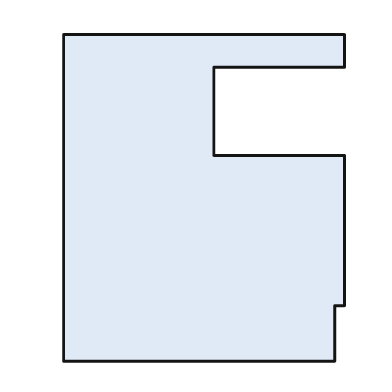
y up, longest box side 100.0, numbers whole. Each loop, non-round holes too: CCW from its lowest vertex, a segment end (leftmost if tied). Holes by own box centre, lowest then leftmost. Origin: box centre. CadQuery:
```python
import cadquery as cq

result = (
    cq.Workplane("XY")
    .moveTo(-43.0, -50.0)
    .lineTo(40.0, -50.0)
    .lineTo(40.0, -33.0)
    .lineTo(43.0, -33.0)
    .lineTo(43.0, 13.0)
    .lineTo(3.0, 13.0)
    .lineTo(3.0, 40.0)
    .lineTo(43.0, 40.0)
    .lineTo(43.0, 50.0)
    .lineTo(-43.0, 50.0)
    .close()
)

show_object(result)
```